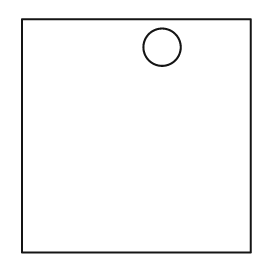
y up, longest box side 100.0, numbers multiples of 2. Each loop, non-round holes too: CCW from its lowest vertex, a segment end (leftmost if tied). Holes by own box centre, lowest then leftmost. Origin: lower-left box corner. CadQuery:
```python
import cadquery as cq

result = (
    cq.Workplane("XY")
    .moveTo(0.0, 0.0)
    .lineTo(98.0, 0.0)
    .lineTo(98.0, 100.0)
    .lineTo(0.0, 100.0)
    .close()
    .moveTo(60.0, 88.0)
    .circle(8.0)
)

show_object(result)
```